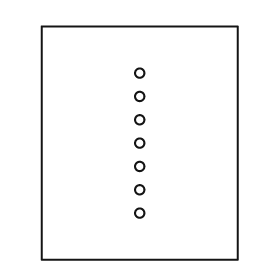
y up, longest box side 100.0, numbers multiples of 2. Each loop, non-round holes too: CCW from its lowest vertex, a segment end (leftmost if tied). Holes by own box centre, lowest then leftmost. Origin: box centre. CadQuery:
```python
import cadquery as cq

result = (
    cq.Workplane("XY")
    .moveTo(-42.0, -50.0)
    .lineTo(42.0, -50.0)
    .lineTo(42.0, 50.0)
    .lineTo(-42.0, 50.0)
    .close()
    .moveTo(0.0, -30.0)
    .circle(2.0)
    .moveTo(0.0, -20.0)
    .circle(2.0)
    .moveTo(0.0, -10.0)
    .circle(2.0)
    .moveTo(0.0, 0.0)
    .circle(2.0)
    .moveTo(0.0, 10.0)
    .circle(2.0)
    .moveTo(0.0, 20.0)
    .circle(2.0)
    .moveTo(0.0, 30.0)
    .circle(2.0)
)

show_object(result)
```